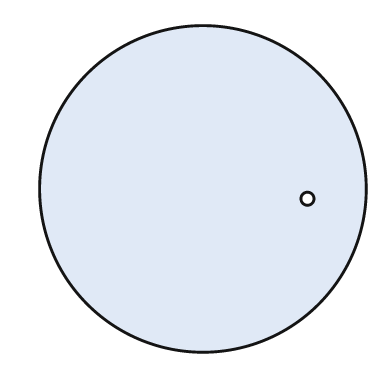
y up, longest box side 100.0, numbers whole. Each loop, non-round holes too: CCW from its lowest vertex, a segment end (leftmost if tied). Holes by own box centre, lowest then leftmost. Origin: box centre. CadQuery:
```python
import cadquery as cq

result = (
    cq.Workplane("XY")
    .moveTo(0.0, 0.0)
    .circle(50.0)
    .moveTo(32.0, -3.0)
    .circle(2.0)
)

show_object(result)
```